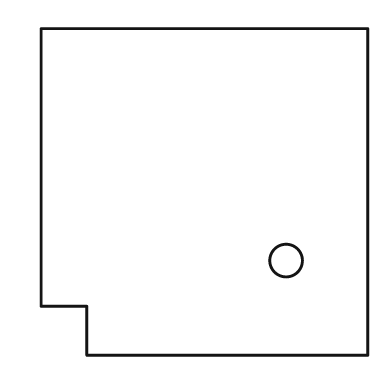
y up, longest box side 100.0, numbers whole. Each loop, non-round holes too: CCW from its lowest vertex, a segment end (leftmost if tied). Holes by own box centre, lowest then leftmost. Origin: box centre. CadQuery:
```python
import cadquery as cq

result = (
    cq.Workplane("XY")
    .moveTo(-36.0, -50.0)
    .lineTo(50.0, -50.0)
    .lineTo(50.0, 50.0)
    .lineTo(-50.0, 50.0)
    .lineTo(-50.0, -35.0)
    .lineTo(-36.0, -35.0)
    .close()
    .moveTo(25.0, -21.0)
    .circle(5.0)
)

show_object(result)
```